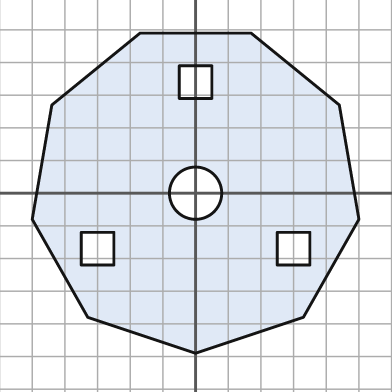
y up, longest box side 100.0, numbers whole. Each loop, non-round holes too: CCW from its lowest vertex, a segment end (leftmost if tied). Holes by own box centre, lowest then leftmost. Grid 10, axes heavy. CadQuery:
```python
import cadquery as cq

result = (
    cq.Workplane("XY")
    .moveTo(0.0, -49.0)
    .lineTo(33.0, -38.0)
    .lineTo(50.0, -8.0)
    .lineTo(44.0, 27.0)
    .lineTo(17.0, 49.0)
    .lineTo(-17.0, 49.0)
    .lineTo(-44.0, 27.0)
    .lineTo(-50.0, -8.0)
    .lineTo(-33.0, -38.0)
    .close()
    .moveTo(-35.0, -22.0)
    .lineTo(-25.0, -22.0)
    .lineTo(-25.0, -12.0)
    .lineTo(-35.0, -12.0)
    .close()
    .moveTo(25.0, -22.0)
    .lineTo(35.0, -22.0)
    .lineTo(35.0, -12.0)
    .lineTo(25.0, -12.0)
    .close()
    .moveTo(0.0, 0.0)
    .circle(8.0)
    .moveTo(-5.0, 29.0)
    .lineTo(5.0, 29.0)
    .lineTo(5.0, 39.0)
    .lineTo(-5.0, 39.0)
    .close()
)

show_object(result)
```